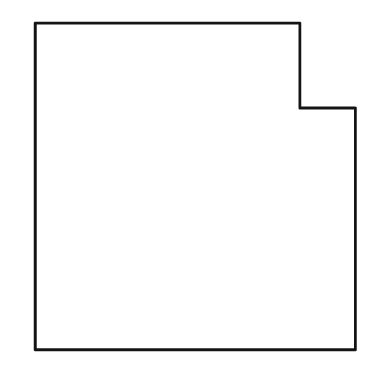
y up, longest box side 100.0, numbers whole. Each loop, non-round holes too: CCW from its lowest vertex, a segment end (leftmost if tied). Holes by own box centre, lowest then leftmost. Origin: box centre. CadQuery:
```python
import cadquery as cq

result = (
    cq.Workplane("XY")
    .moveTo(-49.0, -50.0)
    .lineTo(49.0, -50.0)
    .lineTo(49.0, 24.0)
    .lineTo(32.0, 24.0)
    .lineTo(32.0, 50.0)
    .lineTo(-49.0, 50.0)
    .close()
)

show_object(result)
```